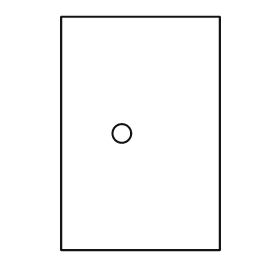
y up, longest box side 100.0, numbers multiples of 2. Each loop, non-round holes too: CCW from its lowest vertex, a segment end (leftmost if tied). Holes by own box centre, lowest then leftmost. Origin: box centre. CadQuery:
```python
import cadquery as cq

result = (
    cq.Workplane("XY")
    .moveTo(-34.0, -50.0)
    .lineTo(34.0, -50.0)
    .lineTo(34.0, 50.0)
    .lineTo(-34.0, 50.0)
    .close()
    .moveTo(-8.0, 0.0)
    .circle(4.0)
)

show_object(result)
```